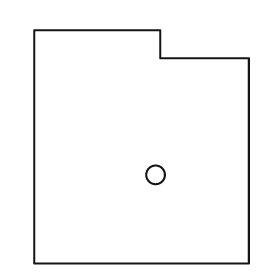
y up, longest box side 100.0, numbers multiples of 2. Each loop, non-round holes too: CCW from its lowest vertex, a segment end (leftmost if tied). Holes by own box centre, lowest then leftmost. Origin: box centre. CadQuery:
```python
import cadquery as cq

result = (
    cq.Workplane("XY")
    .moveTo(-46.0, -50.0)
    .lineTo(46.0, -50.0)
    .lineTo(46.0, 38.0)
    .lineTo(8.0, 38.0)
    .lineTo(8.0, 50.0)
    .lineTo(-46.0, 50.0)
    .close()
    .moveTo(6.0, -12.0)
    .circle(4.0)
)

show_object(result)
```